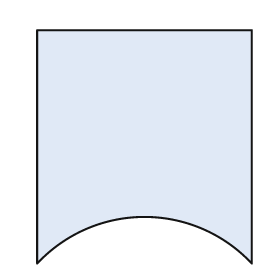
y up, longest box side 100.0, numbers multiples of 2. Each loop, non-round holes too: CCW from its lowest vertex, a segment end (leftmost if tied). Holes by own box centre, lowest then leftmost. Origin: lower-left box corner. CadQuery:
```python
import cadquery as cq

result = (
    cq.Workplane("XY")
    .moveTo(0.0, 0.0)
    .threePointArc((46.0, 20.0), (92.0, 0.0))
    .lineTo(92.0, 100.0)
    .lineTo(0.0, 100.0)
    .close()
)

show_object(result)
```